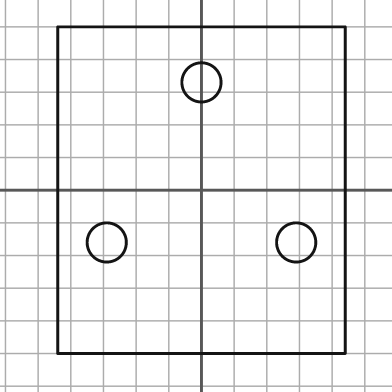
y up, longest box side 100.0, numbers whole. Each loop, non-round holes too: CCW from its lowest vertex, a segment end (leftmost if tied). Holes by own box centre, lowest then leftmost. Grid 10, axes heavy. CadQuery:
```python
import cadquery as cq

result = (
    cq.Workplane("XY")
    .moveTo(-44.0, -50.0)
    .lineTo(44.0, -50.0)
    .lineTo(44.0, 50.0)
    .lineTo(-44.0, 50.0)
    .close()
    .moveTo(-29.0, -16.0)
    .circle(6.0)
    .moveTo(29.0, -16.0)
    .circle(6.0)
    .moveTo(0.0, 33.0)
    .circle(6.0)
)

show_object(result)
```